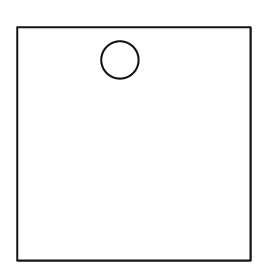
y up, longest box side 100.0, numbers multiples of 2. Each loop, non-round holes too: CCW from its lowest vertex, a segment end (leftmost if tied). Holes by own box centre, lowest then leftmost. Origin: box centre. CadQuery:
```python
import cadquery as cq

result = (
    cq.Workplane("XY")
    .moveTo(-50.0, -50.0)
    .lineTo(50.0, -50.0)
    .lineTo(50.0, 50.0)
    .lineTo(-50.0, 50.0)
    .close()
    .moveTo(-6.0, 36.0)
    .circle(8.0)
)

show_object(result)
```